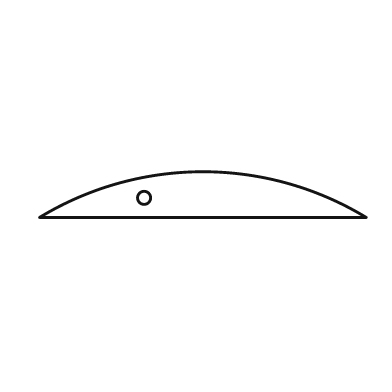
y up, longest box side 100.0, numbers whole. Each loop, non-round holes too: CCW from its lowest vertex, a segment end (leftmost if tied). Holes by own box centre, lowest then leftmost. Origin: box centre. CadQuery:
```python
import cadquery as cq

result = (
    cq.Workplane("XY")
    .moveTo(-50.0, -7.0)
    .lineTo(50.0, -7.0)
    .threePointArc((0.0, 7.0), (-50.0, -7.0))
    .close()
    .moveTo(-18.0, -1.0)
    .circle(2.0)
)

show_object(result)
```